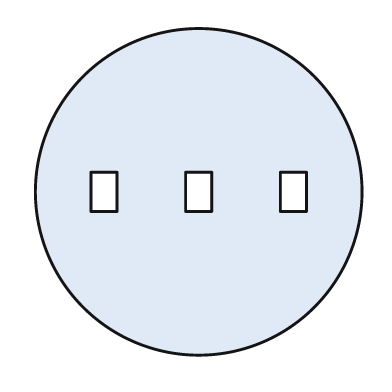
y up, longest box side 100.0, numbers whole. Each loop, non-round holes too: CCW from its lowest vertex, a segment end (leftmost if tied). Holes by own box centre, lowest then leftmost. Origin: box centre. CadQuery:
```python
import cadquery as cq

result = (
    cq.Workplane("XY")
    .moveTo(0.0, 0.0)
    .circle(50.0)
    .moveTo(-33.0, -6.0)
    .lineTo(-25.0, -6.0)
    .lineTo(-25.0, 6.0)
    .lineTo(-33.0, 6.0)
    .close()
    .moveTo(-4.0, -6.0)
    .lineTo(4.0, -6.0)
    .lineTo(4.0, 6.0)
    .lineTo(-4.0, 6.0)
    .close()
    .moveTo(25.0, -6.0)
    .lineTo(33.0, -6.0)
    .lineTo(33.0, 6.0)
    .lineTo(25.0, 6.0)
    .close()
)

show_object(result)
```